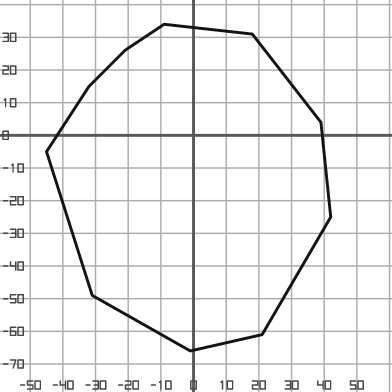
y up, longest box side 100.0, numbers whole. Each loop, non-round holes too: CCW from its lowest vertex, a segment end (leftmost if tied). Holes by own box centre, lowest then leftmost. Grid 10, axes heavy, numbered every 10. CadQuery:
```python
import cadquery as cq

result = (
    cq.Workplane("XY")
    .moveTo(-1.0, -66.0)
    .lineTo(21.0, -61.0)
    .lineTo(42.0, -25.0)
    .lineTo(39.0, 4.0)
    .lineTo(18.0, 31.0)
    .lineTo(-9.0, 34.0)
    .lineTo(-21.0, 26.0)
    .lineTo(-32.0, 15.0)
    .lineTo(-45.0, -5.0)
    .lineTo(-31.0, -49.0)
    .close()
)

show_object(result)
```